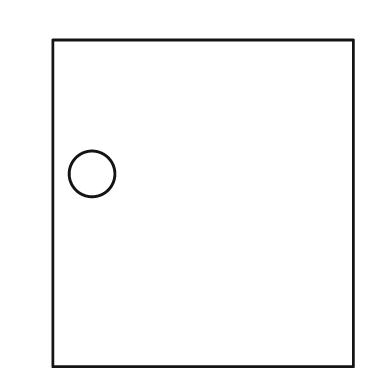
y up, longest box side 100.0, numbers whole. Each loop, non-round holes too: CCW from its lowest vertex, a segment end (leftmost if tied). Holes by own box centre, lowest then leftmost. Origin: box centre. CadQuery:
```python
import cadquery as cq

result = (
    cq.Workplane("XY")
    .moveTo(-46.0, -50.0)
    .lineTo(46.0, -50.0)
    .lineTo(46.0, 50.0)
    .lineTo(-46.0, 50.0)
    .close()
    .moveTo(-34.0, 9.0)
    .circle(7.0)
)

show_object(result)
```